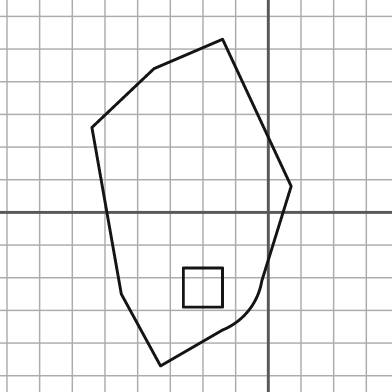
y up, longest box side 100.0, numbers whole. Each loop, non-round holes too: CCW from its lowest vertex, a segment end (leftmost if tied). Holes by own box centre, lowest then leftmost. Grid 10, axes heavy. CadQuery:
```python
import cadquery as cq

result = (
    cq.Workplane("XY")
    .moveTo(-33.0, -47.0)
    .lineTo(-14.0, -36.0)
    .threePointArc((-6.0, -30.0), (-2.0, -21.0))
    .lineTo(7.0, 8.0)
    .lineTo(-14.0, 53.0)
    .lineTo(-35.0, 44.0)
    .lineTo(-54.0, 26.0)
    .lineTo(-45.0, -25.0)
    .close()
    .moveTo(-26.0, -29.0)
    .lineTo(-14.0, -29.0)
    .lineTo(-14.0, -17.0)
    .lineTo(-26.0, -17.0)
    .close()
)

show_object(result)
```